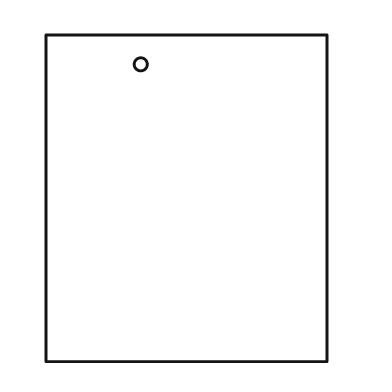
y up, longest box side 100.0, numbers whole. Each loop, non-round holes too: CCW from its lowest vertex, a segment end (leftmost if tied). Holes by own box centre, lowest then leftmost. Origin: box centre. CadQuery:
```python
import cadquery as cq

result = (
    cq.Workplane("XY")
    .moveTo(-43.0, -50.0)
    .lineTo(43.0, -50.0)
    .lineTo(43.0, 50.0)
    .lineTo(-43.0, 50.0)
    .close()
    .moveTo(-14.0, 41.0)
    .circle(2.0)
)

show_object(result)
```